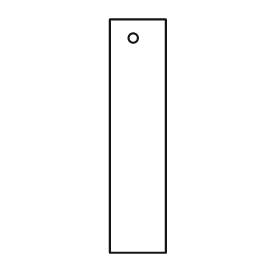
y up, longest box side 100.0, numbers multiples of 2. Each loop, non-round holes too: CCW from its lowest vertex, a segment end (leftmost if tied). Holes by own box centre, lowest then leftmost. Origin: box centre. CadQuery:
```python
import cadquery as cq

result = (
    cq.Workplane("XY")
    .moveTo(-12.0, -50.0)
    .lineTo(12.0, -50.0)
    .lineTo(12.0, 50.0)
    .lineTo(-12.0, 50.0)
    .close()
    .moveTo(-2.0, 42.0)
    .circle(2.0)
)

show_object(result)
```